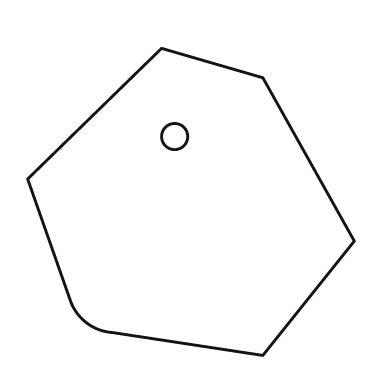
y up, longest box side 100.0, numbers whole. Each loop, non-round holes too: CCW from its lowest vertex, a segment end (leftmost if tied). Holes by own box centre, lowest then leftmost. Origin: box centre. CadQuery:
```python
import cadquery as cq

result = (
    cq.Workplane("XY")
    .moveTo(22.0, -47.0)
    .lineTo(50.0, -12.0)
    .lineTo(22.0, 38.0)
    .lineTo(-9.0, 47.0)
    .lineTo(-50.0, 7.0)
    .lineTo(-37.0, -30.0)
    .threePointArc((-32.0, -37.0), (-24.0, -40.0))
    .close()
    .moveTo(-5.0, 20.0)
    .circle(4.0)
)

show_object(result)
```